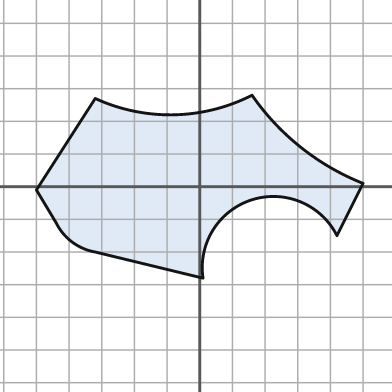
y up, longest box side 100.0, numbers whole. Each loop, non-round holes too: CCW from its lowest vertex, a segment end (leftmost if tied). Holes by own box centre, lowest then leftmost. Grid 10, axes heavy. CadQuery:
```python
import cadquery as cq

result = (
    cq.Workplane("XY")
    .moveTo(1.0, -28.0)
    .threePointArc((16.0, -4.0), (42.0, -15.0))
    .lineTo(50.0, 1.0)
    .threePointArc((31.0, 12.0), (16.0, 28.0))
    .threePointArc((-8.0, 22.0), (-32.0, 27.0))
    .lineTo(-50.0, -1.0)
    .lineTo(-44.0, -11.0)
    .threePointArc((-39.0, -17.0), (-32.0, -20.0))
    .close()
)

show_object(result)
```